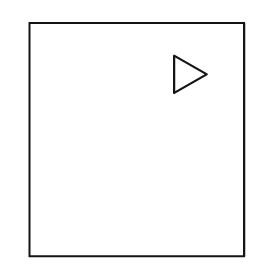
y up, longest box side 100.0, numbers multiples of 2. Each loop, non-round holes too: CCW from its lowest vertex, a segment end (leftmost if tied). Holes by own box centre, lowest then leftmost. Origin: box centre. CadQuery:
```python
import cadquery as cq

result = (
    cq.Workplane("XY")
    .moveTo(-46.0, -50.0)
    .lineTo(46.0, -50.0)
    .lineTo(46.0, 50.0)
    .lineTo(-46.0, 50.0)
    .close()
    .moveTo(16.0, 20.0)
    .lineTo(30.0, 28.0)
    .lineTo(16.0, 36.0)
    .close()
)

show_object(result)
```